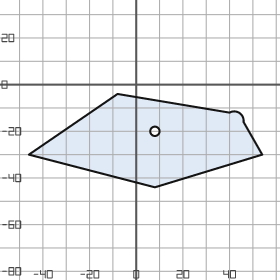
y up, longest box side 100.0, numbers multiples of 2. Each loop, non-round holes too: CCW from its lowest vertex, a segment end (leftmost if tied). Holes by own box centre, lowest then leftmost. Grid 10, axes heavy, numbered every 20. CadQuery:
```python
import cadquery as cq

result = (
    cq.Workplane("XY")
    .moveTo(8.0, -44.0)
    .lineTo(54.0, -30.0)
    .lineTo(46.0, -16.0)
    .threePointArc((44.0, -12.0), (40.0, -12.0))
    .lineTo(-8.0, -4.0)
    .lineTo(-46.0, -30.0)
    .close()
    .moveTo(8.0, -20.0)
    .circle(2.0)
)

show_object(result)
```